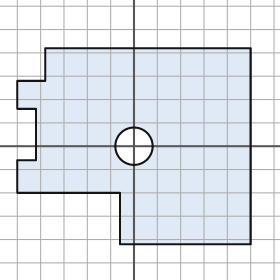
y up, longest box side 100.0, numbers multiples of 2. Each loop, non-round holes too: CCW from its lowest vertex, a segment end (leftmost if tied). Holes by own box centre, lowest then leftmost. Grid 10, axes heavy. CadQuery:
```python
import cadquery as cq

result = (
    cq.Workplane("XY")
    .moveTo(-6.0, -42.0)
    .lineTo(50.0, -42.0)
    .lineTo(50.0, 42.0)
    .lineTo(-38.0, 42.0)
    .lineTo(-38.0, 28.0)
    .lineTo(-50.0, 28.0)
    .lineTo(-50.0, 16.0)
    .lineTo(-42.0, 16.0)
    .lineTo(-42.0, -6.0)
    .lineTo(-50.0, -6.0)
    .lineTo(-50.0, -20.0)
    .lineTo(-6.0, -20.0)
    .close()
    .moveTo(0.0, 0.0)
    .circle(8.0)
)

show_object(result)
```